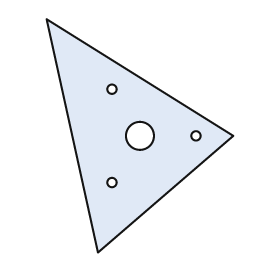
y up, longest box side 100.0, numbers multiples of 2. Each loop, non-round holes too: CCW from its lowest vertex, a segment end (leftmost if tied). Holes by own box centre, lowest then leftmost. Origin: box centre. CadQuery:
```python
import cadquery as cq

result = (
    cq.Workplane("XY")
    .moveTo(-18.0, -50.0)
    .lineTo(40.0, 0.0)
    .lineTo(-40.0, 50.0)
    .close()
    .moveTo(-12.0, -20.0)
    .circle(2.0)
    .moveTo(0.0, 0.0)
    .circle(6.0)
    .moveTo(24.0, 0.0)
    .circle(2.0)
    .moveTo(-12.0, 20.0)
    .circle(2.0)
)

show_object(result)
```